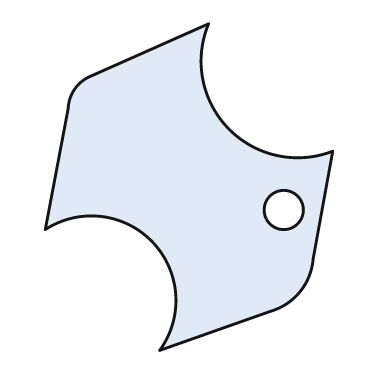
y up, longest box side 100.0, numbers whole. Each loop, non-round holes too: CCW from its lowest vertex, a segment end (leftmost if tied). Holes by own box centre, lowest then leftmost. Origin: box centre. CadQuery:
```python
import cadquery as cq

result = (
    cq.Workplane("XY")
    .moveTo(-9.0, -50.0)
    .lineTo(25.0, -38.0)
    .threePointArc((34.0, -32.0), (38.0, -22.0))
    .lineTo(44.0, 11.0)
    .threePointArc((12.0, 18.0), (6.0, 50.0))
    .lineTo(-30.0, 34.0)
    .threePointArc((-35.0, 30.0), (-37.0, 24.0))
    .lineTo(-44.0, -13.0)
    .threePointArc((-11.0, -17.0), (-9.0, -50.0))
    .close()
    .moveTo(29.0, -7.0)
    .circle(6.0)
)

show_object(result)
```